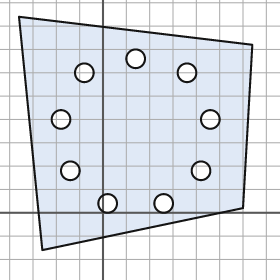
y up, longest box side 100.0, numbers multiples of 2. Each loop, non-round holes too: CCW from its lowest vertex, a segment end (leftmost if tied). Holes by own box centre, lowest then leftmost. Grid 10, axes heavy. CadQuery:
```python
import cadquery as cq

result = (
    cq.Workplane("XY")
    .moveTo(-26.0, -16.0)
    .lineTo(60.0, 2.0)
    .lineTo(64.0, 72.0)
    .lineTo(-36.0, 84.0)
    .close()
    .moveTo(2.0, 4.0)
    .circle(4.0)
    .moveTo(26.0, 4.0)
    .circle(4.0)
    .moveTo(-14.0, 18.0)
    .circle(4.0)
    .moveTo(42.0, 18.0)
    .circle(4.0)
    .moveTo(-18.0, 40.0)
    .circle(4.0)
    .moveTo(46.0, 40.0)
    .circle(4.0)
    .moveTo(-8.0, 60.0)
    .circle(4.0)
    .moveTo(36.0, 60.0)
    .circle(4.0)
    .moveTo(14.0, 66.0)
    .circle(4.0)
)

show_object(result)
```